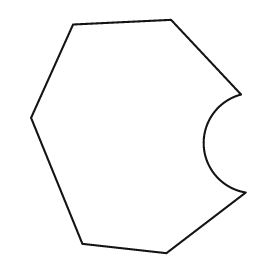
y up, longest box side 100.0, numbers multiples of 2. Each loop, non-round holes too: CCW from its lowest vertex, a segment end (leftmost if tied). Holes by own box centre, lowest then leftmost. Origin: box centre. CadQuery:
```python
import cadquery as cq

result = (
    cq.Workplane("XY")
    .moveTo(12.0, -50.0)
    .lineTo(46.0, -24.0)
    .threePointArc((28.0, -4.0), (44.0, 18.0))
    .lineTo(14.0, 50.0)
    .lineTo(-28.0, 48.0)
    .lineTo(-46.0, 8.0)
    .lineTo(-24.0, -46.0)
    .close()
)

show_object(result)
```